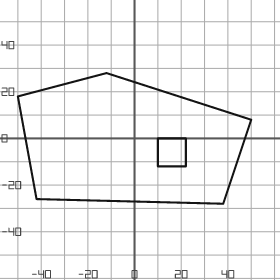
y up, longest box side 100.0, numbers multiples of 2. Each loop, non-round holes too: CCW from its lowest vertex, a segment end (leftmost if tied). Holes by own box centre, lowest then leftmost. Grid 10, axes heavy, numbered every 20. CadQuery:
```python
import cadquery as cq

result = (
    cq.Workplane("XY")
    .moveTo(38.0, -28.0)
    .lineTo(50.0, 8.0)
    .lineTo(-12.0, 28.0)
    .lineTo(-50.0, 18.0)
    .lineTo(-42.0, -26.0)
    .close()
    .moveTo(10.0, -12.0)
    .lineTo(22.0, -12.0)
    .lineTo(22.0, 0.0)
    .lineTo(10.0, 0.0)
    .close()
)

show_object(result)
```